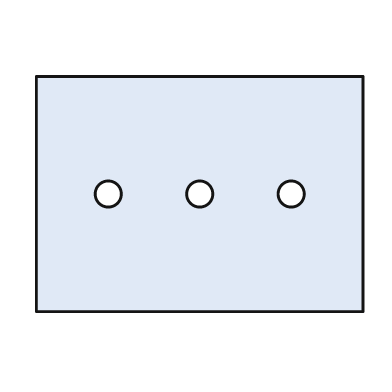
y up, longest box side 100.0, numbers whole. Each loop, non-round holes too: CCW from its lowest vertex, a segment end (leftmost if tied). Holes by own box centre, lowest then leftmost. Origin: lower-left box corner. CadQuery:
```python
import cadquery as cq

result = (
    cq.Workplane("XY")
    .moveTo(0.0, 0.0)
    .lineTo(100.0, 0.0)
    .lineTo(100.0, 72.0)
    .lineTo(0.0, 72.0)
    .close()
    .moveTo(22.0, 36.0)
    .circle(4.0)
    .moveTo(50.0, 36.0)
    .circle(4.0)
    .moveTo(78.0, 36.0)
    .circle(4.0)
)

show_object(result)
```